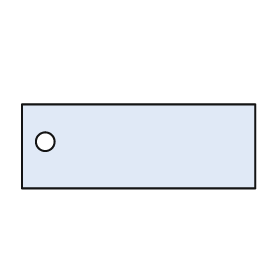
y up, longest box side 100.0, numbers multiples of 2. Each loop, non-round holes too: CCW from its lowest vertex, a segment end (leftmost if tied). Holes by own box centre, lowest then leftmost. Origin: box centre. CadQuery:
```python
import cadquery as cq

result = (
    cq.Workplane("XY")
    .moveTo(-50.0, -18.0)
    .lineTo(50.0, -18.0)
    .lineTo(50.0, 18.0)
    .lineTo(-50.0, 18.0)
    .close()
    .moveTo(-40.0, 2.0)
    .circle(4.0)
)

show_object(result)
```